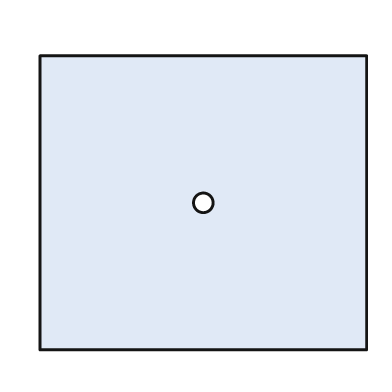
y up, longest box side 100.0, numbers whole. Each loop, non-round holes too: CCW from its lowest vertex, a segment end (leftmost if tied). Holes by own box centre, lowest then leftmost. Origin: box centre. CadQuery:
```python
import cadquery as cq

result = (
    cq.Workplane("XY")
    .moveTo(-50.0, -45.0)
    .lineTo(50.0, -45.0)
    .lineTo(50.0, 45.0)
    .lineTo(-50.0, 45.0)
    .close()
    .moveTo(0.0, 0.0)
    .circle(3.0)
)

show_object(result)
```